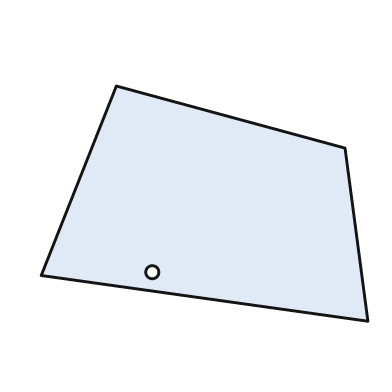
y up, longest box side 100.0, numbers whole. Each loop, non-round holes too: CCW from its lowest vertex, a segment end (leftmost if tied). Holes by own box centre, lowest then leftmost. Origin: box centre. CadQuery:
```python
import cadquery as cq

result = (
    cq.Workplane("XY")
    .moveTo(50.0, -36.0)
    .lineTo(43.0, 17.0)
    .lineTo(-27.0, 36.0)
    .lineTo(-50.0, -22.0)
    .close()
    .moveTo(-16.0, -21.0)
    .circle(2.0)
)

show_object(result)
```